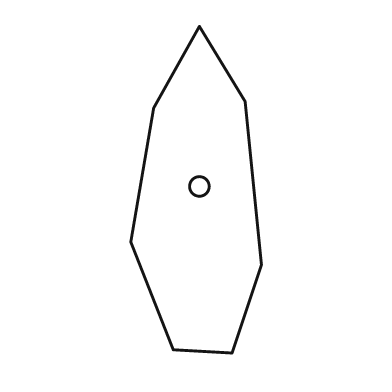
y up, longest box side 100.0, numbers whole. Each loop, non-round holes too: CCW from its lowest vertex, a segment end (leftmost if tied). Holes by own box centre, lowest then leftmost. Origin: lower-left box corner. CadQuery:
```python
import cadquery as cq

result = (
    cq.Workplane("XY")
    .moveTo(31.0, 0.0)
    .lineTo(40.0, 27.0)
    .lineTo(35.0, 77.0)
    .lineTo(21.0, 100.0)
    .lineTo(7.0, 75.0)
    .lineTo(0.0, 34.0)
    .lineTo(13.0, 1.0)
    .close()
    .moveTo(21.0, 51.0)
    .circle(3.0)
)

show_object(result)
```